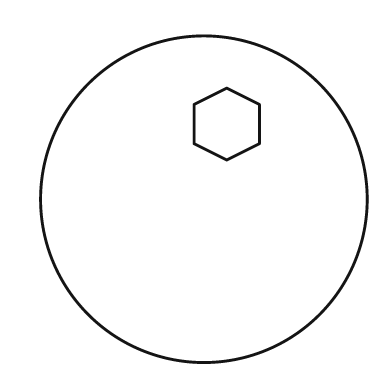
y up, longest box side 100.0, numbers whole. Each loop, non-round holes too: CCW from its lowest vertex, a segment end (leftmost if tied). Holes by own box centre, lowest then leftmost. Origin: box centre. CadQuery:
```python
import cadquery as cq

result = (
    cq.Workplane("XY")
    .moveTo(0.0, 0.0)
    .circle(50.0)
    .moveTo(7.0, 12.0)
    .lineTo(17.0, 17.0)
    .lineTo(17.0, 29.0)
    .lineTo(7.0, 34.0)
    .lineTo(-3.0, 29.0)
    .lineTo(-3.0, 17.0)
    .close()
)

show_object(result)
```